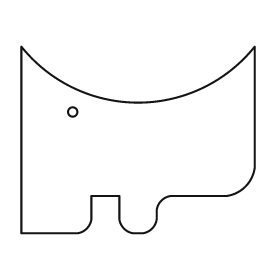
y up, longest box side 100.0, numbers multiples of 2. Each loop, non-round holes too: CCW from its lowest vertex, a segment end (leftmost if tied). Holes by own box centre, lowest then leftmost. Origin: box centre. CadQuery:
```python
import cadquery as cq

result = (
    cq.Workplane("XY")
    .moveTo(-50.0, -40.0)
    .lineTo(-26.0, -40.0)
    .threePointArc((-22.0, -38.0), (-20.0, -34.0))
    .lineTo(-20.0, -24.0)
    .lineTo(-8.0, -24.0)
    .lineTo(-8.0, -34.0)
    .threePointArc((-6.0, -38.0), (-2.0, -40.0))
    .lineTo(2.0, -40.0)
    .threePointArc((6.0, -38.0), (8.0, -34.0))
    .lineTo(8.0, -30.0)
    .threePointArc((10.0, -26.0), (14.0, -24.0))
    .lineTo(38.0, -24.0)
    .threePointArc((46.0, -20.0), (50.0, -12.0))
    .lineTo(50.0, 40.0)
    .threePointArc((0.0, 16.0), (-50.0, 40.0))
    .close()
    .moveTo(-28.0, 12.0)
    .circle(2.0)
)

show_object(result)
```